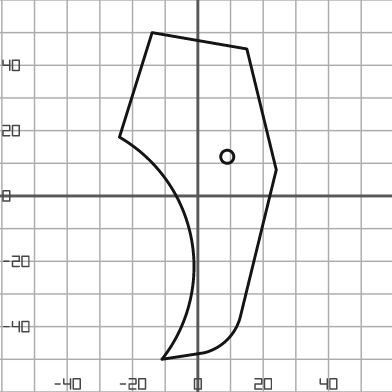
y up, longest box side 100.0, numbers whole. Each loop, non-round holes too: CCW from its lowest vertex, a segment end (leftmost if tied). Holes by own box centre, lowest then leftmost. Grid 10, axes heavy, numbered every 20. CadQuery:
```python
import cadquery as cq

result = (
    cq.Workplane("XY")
    .moveTo(-11.0, -50.0)
    .lineTo(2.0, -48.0)
    .threePointArc((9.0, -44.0), (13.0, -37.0))
    .lineTo(24.0, 8.0)
    .lineTo(15.0, 45.0)
    .lineTo(-14.0, 50.0)
    .lineTo(-24.0, 18.0)
    .threePointArc((-2.0, -13.0), (-11.0, -50.0))
    .close()
    .moveTo(9.0, 12.0)
    .circle(2.0)
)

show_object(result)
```